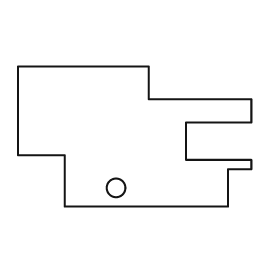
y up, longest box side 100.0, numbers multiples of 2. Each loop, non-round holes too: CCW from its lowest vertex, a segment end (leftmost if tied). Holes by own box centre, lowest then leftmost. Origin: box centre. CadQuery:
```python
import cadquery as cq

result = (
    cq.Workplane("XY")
    .moveTo(-30.0, -30.0)
    .lineTo(40.0, -30.0)
    .lineTo(40.0, -14.0)
    .lineTo(50.0, -14.0)
    .lineTo(50.0, -10.0)
    .lineTo(22.0, -10.0)
    .lineTo(22.0, 6.0)
    .lineTo(50.0, 6.0)
    .lineTo(50.0, 16.0)
    .lineTo(6.0, 16.0)
    .lineTo(6.0, 30.0)
    .lineTo(-50.0, 30.0)
    .lineTo(-50.0, -8.0)
    .lineTo(-30.0, -8.0)
    .close()
    .moveTo(-8.0, -22.0)
    .circle(4.0)
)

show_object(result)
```